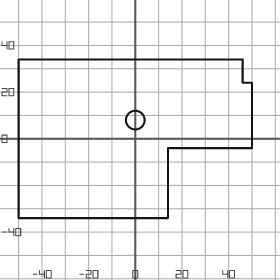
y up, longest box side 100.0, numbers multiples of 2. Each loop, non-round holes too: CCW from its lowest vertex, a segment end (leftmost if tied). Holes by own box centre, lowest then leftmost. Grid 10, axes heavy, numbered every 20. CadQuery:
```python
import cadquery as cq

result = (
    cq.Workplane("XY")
    .moveTo(-50.0, -34.0)
    .lineTo(14.0, -34.0)
    .lineTo(14.0, -4.0)
    .lineTo(50.0, -4.0)
    .lineTo(50.0, 24.0)
    .lineTo(46.0, 24.0)
    .lineTo(46.0, 34.0)
    .lineTo(-50.0, 34.0)
    .close()
    .moveTo(0.0, 8.0)
    .circle(4.0)
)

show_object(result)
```